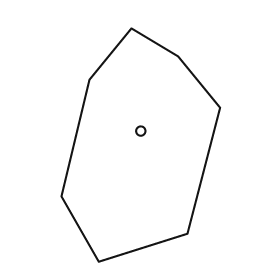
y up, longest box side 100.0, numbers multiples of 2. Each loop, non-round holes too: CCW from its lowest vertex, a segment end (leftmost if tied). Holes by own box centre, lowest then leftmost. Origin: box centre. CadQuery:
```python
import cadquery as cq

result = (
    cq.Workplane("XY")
    .moveTo(-18.0, -50.0)
    .lineTo(20.0, -38.0)
    .lineTo(34.0, 16.0)
    .lineTo(16.0, 38.0)
    .lineTo(-4.0, 50.0)
    .lineTo(-22.0, 28.0)
    .lineTo(-34.0, -22.0)
    .close()
    .moveTo(0.0, 6.0)
    .circle(2.0)
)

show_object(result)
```